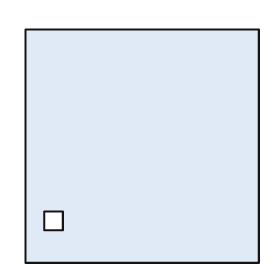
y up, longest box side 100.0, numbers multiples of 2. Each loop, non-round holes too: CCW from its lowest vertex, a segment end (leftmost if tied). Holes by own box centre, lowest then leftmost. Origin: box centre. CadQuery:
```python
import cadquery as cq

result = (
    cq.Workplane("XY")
    .moveTo(-50.0, -50.0)
    .lineTo(50.0, -50.0)
    .lineTo(50.0, 50.0)
    .lineTo(-50.0, 50.0)
    .close()
    .moveTo(-42.0, -36.0)
    .lineTo(-34.0, -36.0)
    .lineTo(-34.0, -28.0)
    .lineTo(-42.0, -28.0)
    .close()
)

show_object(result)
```